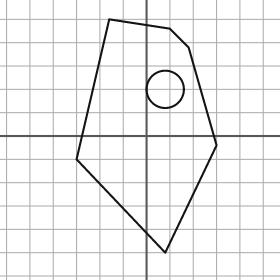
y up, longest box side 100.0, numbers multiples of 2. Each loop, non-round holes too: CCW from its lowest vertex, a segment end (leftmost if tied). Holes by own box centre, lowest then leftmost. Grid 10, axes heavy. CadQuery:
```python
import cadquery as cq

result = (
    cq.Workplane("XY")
    .moveTo(8.0, -50.0)
    .lineTo(30.0, -4.0)
    .lineTo(18.0, 38.0)
    .lineTo(10.0, 46.0)
    .lineTo(-16.0, 50.0)
    .lineTo(-30.0, -10.0)
    .close()
    .moveTo(8.0, 20.0)
    .circle(8.0)
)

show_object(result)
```